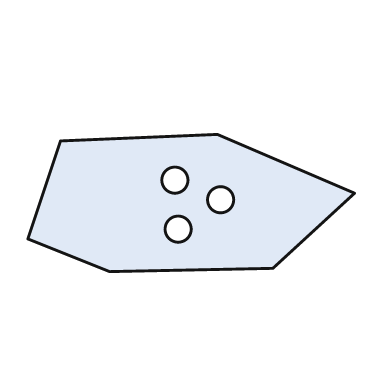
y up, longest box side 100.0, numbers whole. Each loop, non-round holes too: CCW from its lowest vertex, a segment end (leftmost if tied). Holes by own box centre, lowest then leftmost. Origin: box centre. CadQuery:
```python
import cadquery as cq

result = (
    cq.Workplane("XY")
    .moveTo(-25.0, -21.0)
    .lineTo(25.0, -20.0)
    .lineTo(50.0, 3.0)
    .lineTo(8.0, 21.0)
    .lineTo(-40.0, 19.0)
    .lineTo(-50.0, -11.0)
    .close()
    .moveTo(-4.0, -8.0)
    .circle(4.0)
    .moveTo(9.0, 1.0)
    .circle(4.0)
    .moveTo(-5.0, 7.0)
    .circle(4.0)
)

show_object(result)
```